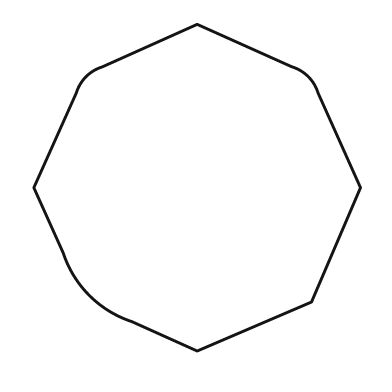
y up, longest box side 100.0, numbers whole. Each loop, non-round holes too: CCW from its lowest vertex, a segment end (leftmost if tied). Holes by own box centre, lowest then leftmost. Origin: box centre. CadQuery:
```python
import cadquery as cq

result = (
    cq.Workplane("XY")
    .moveTo(0.0, -50.0)
    .lineTo(35.0, -35.0)
    .lineTo(50.0, 0.0)
    .lineTo(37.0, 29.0)
    .threePointArc((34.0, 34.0), (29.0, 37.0))
    .lineTo(0.0, 50.0)
    .lineTo(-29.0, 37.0)
    .threePointArc((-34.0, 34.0), (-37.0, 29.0))
    .lineTo(-50.0, 0.0)
    .lineTo(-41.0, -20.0)
    .threePointArc((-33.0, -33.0), (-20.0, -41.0))
    .close()
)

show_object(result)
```